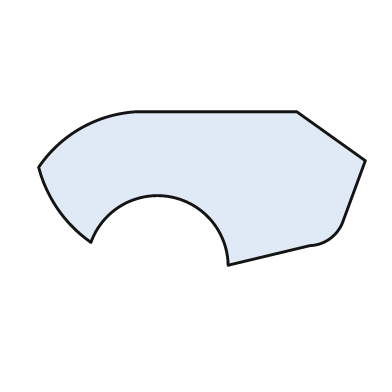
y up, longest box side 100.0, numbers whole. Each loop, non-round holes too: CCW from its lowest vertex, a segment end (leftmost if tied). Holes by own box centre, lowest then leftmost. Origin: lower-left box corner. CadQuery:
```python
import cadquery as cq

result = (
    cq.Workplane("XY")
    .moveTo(58.0, 0.0)
    .lineTo(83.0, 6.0)
    .threePointArc((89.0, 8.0), (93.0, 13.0))
    .lineTo(100.0, 32.0)
    .lineTo(79.0, 47.0)
    .lineTo(30.0, 47.0)
    .threePointArc((13.0, 42.0), (0.0, 30.0))
    .threePointArc((6.0, 17.0), (16.0, 7.0))
    .threePointArc((40.0, 21.0), (58.0, 0.0))
    .close()
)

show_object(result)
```